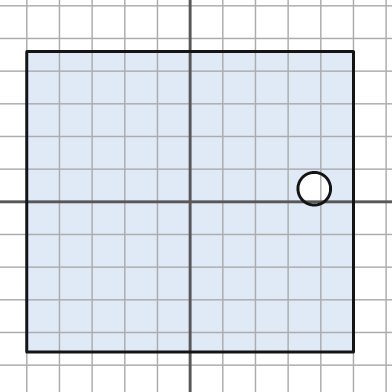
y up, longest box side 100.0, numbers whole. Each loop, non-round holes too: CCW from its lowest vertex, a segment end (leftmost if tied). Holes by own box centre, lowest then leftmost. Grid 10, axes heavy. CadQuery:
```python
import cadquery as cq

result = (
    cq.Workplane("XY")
    .moveTo(-50.0, -46.0)
    .lineTo(50.0, -46.0)
    .lineTo(50.0, 46.0)
    .lineTo(-50.0, 46.0)
    .close()
    .moveTo(38.0, 4.0)
    .circle(5.0)
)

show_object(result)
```